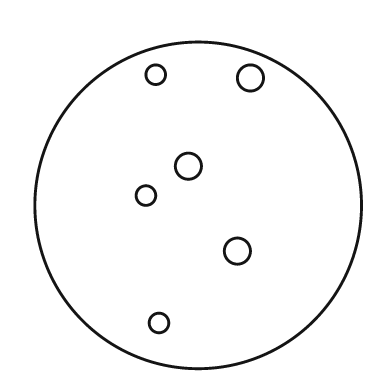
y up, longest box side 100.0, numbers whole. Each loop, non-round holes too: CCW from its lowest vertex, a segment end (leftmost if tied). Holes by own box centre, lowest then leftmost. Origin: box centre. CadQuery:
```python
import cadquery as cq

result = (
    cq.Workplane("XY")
    .moveTo(0.0, 0.0)
    .circle(50.0)
    .moveTo(-12.0, -36.0)
    .circle(3.0)
    .moveTo(12.0, -14.0)
    .circle(4.0)
    .moveTo(-16.0, 3.0)
    .circle(3.0)
    .moveTo(-3.0, 12.0)
    .circle(4.0)
    .moveTo(16.0, 39.0)
    .circle(4.0)
    .moveTo(-13.0, 40.0)
    .circle(3.0)
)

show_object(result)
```